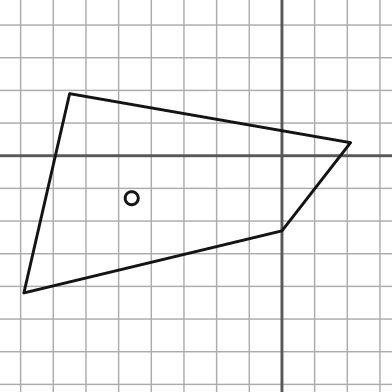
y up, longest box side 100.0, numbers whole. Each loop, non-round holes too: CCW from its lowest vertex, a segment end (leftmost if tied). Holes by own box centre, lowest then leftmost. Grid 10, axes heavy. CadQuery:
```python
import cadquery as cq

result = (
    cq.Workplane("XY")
    .moveTo(-79.0, -42.0)
    .lineTo(0.0, -23.0)
    .lineTo(21.0, 4.0)
    .lineTo(-65.0, 19.0)
    .close()
    .moveTo(-46.0, -13.0)
    .circle(2.0)
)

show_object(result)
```